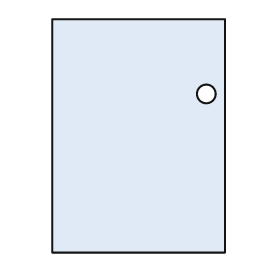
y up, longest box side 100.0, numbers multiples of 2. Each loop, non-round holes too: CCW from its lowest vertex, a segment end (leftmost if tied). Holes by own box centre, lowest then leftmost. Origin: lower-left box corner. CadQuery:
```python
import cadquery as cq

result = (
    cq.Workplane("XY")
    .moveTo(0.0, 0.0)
    .lineTo(74.0, 0.0)
    .lineTo(74.0, 100.0)
    .lineTo(0.0, 100.0)
    .close()
    .moveTo(66.0, 68.0)
    .circle(4.0)
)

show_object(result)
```